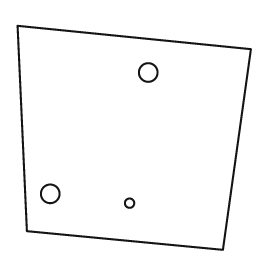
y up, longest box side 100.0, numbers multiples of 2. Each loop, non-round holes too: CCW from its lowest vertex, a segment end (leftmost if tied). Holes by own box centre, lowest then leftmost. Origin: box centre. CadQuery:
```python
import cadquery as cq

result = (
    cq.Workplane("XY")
    .moveTo(38.0, -48.0)
    .lineTo(50.0, 38.0)
    .lineTo(-50.0, 48.0)
    .lineTo(-46.0, -40.0)
    .close()
    .moveTo(-2.0, -28.0)
    .circle(2.0)
    .moveTo(-36.0, -24.0)
    .circle(4.0)
    .moveTo(6.0, 28.0)
    .circle(4.0)
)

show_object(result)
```